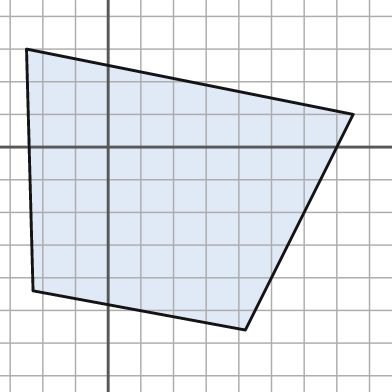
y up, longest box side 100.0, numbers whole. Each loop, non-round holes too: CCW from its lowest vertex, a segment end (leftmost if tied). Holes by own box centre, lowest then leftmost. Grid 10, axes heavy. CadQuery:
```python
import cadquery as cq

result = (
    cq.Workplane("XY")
    .moveTo(42.0, -56.0)
    .lineTo(75.0, 10.0)
    .lineTo(-25.0, 30.0)
    .lineTo(-23.0, -44.0)
    .close()
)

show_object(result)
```